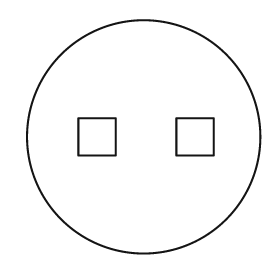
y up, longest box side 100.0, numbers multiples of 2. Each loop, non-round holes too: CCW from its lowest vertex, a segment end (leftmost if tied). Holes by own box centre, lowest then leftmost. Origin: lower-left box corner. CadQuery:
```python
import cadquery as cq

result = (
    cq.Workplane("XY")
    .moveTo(50.0, 50.0)
    .circle(50.0)
    .moveTo(22.0, 42.0)
    .lineTo(38.0, 42.0)
    .lineTo(38.0, 58.0)
    .lineTo(22.0, 58.0)
    .close()
    .moveTo(64.0, 42.0)
    .lineTo(80.0, 42.0)
    .lineTo(80.0, 58.0)
    .lineTo(64.0, 58.0)
    .close()
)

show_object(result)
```